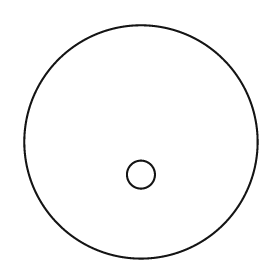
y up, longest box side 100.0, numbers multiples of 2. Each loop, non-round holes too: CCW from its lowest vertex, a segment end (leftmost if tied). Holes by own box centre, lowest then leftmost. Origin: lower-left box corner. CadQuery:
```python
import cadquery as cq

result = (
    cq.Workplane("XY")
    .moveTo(50.0, 50.0)
    .circle(50.0)
    .moveTo(50.0, 36.0)
    .circle(6.0)
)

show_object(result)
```